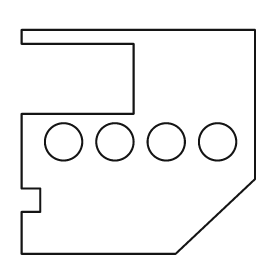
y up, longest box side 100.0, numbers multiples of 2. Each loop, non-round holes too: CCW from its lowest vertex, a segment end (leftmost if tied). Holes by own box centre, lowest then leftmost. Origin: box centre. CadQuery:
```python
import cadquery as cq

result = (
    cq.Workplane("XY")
    .moveTo(-50.0, -48.0)
    .lineTo(16.0, -48.0)
    .lineTo(50.0, -16.0)
    .lineTo(50.0, 48.0)
    .lineTo(-50.0, 48.0)
    .lineTo(-50.0, 42.0)
    .lineTo(-2.0, 42.0)
    .lineTo(-2.0, 12.0)
    .lineTo(-50.0, 12.0)
    .lineTo(-50.0, -20.0)
    .lineTo(-42.0, -20.0)
    .lineTo(-42.0, -30.0)
    .lineTo(-50.0, -30.0)
    .close()
    .moveTo(-32.0, 0.0)
    .circle(8.0)
    .moveTo(-10.0, 0.0)
    .circle(8.0)
    .moveTo(12.0, 0.0)
    .circle(8.0)
    .moveTo(34.0, 0.0)
    .circle(8.0)
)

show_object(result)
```